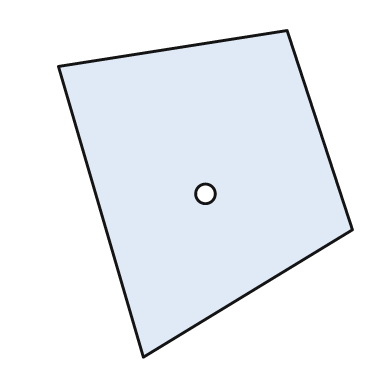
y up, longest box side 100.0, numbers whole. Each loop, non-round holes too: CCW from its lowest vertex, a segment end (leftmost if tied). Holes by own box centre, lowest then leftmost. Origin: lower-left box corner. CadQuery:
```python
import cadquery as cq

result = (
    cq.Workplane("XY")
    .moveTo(26.0, 0.0)
    .lineTo(90.0, 39.0)
    .lineTo(70.0, 100.0)
    .lineTo(0.0, 89.0)
    .close()
    .moveTo(45.0, 50.0)
    .circle(3.0)
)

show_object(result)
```